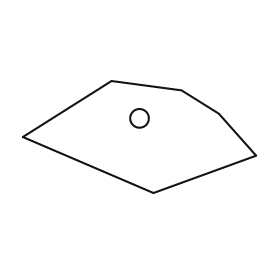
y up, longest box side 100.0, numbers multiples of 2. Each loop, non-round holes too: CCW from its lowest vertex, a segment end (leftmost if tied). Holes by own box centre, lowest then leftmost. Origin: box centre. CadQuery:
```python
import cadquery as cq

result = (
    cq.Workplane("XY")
    .moveTo(6.0, -24.0)
    .lineTo(50.0, -8.0)
    .lineTo(34.0, 10.0)
    .lineTo(18.0, 20.0)
    .lineTo(-12.0, 24.0)
    .lineTo(-50.0, 0.0)
    .close()
    .moveTo(0.0, 8.0)
    .circle(4.0)
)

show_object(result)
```